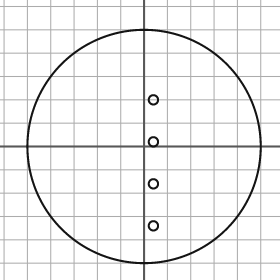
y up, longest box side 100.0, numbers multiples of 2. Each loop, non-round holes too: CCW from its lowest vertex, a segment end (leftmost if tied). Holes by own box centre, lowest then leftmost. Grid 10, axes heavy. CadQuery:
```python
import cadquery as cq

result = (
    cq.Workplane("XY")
    .moveTo(0.0, 0.0)
    .circle(50.0)
    .moveTo(4.0, -34.0)
    .circle(2.0)
    .moveTo(4.0, -16.0)
    .circle(2.0)
    .moveTo(4.0, 2.0)
    .circle(2.0)
    .moveTo(4.0, 20.0)
    .circle(2.0)
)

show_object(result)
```